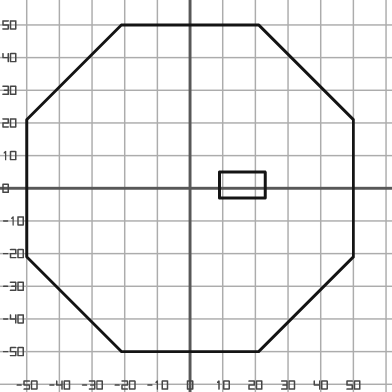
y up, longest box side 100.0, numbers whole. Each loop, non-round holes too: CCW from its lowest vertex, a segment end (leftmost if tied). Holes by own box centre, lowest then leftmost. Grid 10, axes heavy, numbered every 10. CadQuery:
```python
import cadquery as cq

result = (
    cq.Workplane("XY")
    .moveTo(-21.0, -50.0)
    .lineTo(21.0, -50.0)
    .lineTo(50.0, -21.0)
    .lineTo(50.0, 21.0)
    .lineTo(21.0, 50.0)
    .lineTo(-21.0, 50.0)
    .lineTo(-50.0, 21.0)
    .lineTo(-50.0, -21.0)
    .close()
    .moveTo(9.0, -3.0)
    .lineTo(23.0, -3.0)
    .lineTo(23.0, 5.0)
    .lineTo(9.0, 5.0)
    .close()
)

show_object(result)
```